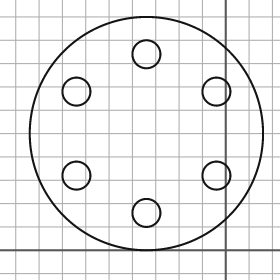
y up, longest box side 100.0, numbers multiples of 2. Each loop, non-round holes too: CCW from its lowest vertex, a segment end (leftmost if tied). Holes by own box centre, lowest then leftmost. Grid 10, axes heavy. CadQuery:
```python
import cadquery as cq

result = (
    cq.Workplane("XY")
    .moveTo(-34.0, 50.0)
    .circle(50.0)
    .moveTo(-34.0, 16.0)
    .circle(6.0)
    .moveTo(-64.0, 32.0)
    .circle(6.0)
    .moveTo(-4.0, 32.0)
    .circle(6.0)
    .moveTo(-64.0, 68.0)
    .circle(6.0)
    .moveTo(-4.0, 68.0)
    .circle(6.0)
    .moveTo(-34.0, 84.0)
    .circle(6.0)
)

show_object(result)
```